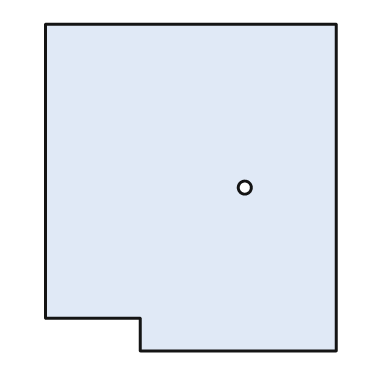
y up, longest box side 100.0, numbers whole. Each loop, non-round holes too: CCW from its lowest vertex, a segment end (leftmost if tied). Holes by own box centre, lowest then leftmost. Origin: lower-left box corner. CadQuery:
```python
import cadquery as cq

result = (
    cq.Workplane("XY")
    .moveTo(29.0, 0.0)
    .lineTo(89.0, 0.0)
    .lineTo(89.0, 100.0)
    .lineTo(0.0, 100.0)
    .lineTo(0.0, 10.0)
    .lineTo(29.0, 10.0)
    .close()
    .moveTo(61.0, 50.0)
    .circle(2.0)
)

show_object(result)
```